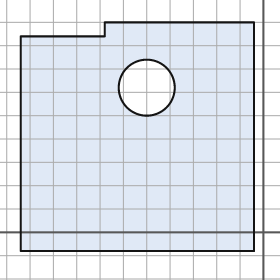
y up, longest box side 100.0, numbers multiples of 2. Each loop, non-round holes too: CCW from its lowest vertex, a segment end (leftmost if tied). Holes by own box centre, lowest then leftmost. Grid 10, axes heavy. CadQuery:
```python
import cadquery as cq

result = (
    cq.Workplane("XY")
    .moveTo(-104.0, -8.0)
    .lineTo(-4.0, -8.0)
    .lineTo(-4.0, 90.0)
    .lineTo(-68.0, 90.0)
    .lineTo(-68.0, 84.0)
    .lineTo(-104.0, 84.0)
    .close()
    .moveTo(-50.0, 62.0)
    .circle(12.0)
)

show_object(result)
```